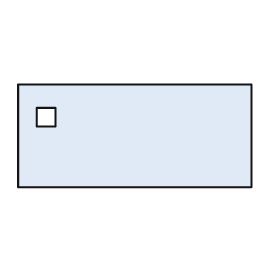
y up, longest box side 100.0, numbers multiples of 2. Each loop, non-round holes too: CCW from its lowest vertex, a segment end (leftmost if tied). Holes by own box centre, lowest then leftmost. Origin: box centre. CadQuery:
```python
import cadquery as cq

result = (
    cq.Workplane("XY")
    .moveTo(-50.0, -22.0)
    .lineTo(50.0, -22.0)
    .lineTo(50.0, 22.0)
    .lineTo(-50.0, 22.0)
    .close()
    .moveTo(-42.0, 4.0)
    .lineTo(-34.0, 4.0)
    .lineTo(-34.0, 12.0)
    .lineTo(-42.0, 12.0)
    .close()
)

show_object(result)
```